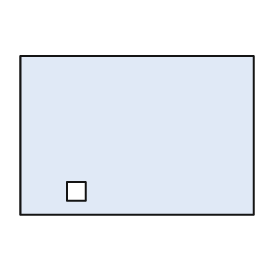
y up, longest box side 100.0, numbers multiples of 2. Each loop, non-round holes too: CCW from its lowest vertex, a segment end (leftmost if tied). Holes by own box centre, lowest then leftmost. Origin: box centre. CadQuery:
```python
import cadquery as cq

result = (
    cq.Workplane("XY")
    .moveTo(-50.0, -34.0)
    .lineTo(50.0, -34.0)
    .lineTo(50.0, 34.0)
    .lineTo(-50.0, 34.0)
    .close()
    .moveTo(-30.0, -28.0)
    .lineTo(-22.0, -28.0)
    .lineTo(-22.0, -20.0)
    .lineTo(-30.0, -20.0)
    .close()
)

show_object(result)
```